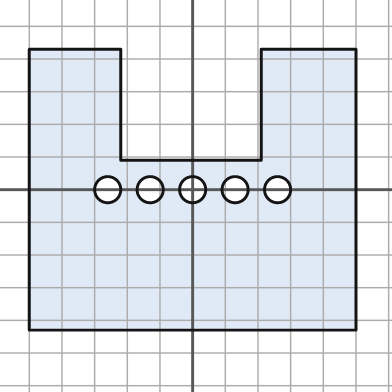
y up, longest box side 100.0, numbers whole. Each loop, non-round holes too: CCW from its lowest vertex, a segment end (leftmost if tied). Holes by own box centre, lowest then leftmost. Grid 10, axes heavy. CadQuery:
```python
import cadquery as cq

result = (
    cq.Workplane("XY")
    .moveTo(-50.0, -43.0)
    .lineTo(50.0, -43.0)
    .lineTo(50.0, 43.0)
    .lineTo(21.0, 43.0)
    .lineTo(21.0, 9.0)
    .lineTo(-22.0, 9.0)
    .lineTo(-22.0, 43.0)
    .lineTo(-50.0, 43.0)
    .close()
    .moveTo(-26.0, 0.0)
    .circle(4.0)
    .moveTo(-13.0, 0.0)
    .circle(4.0)
    .moveTo(0.0, 0.0)
    .circle(4.0)
    .moveTo(13.0, 0.0)
    .circle(4.0)
    .moveTo(26.0, 0.0)
    .circle(4.0)
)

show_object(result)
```